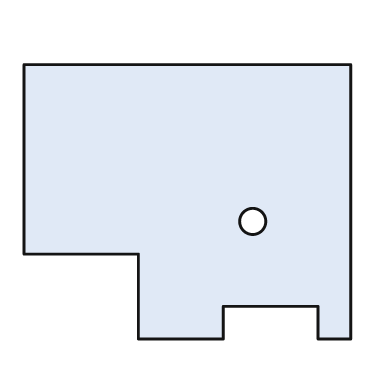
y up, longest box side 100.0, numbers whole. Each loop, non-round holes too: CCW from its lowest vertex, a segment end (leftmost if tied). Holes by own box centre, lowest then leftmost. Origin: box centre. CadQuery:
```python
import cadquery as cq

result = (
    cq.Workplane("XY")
    .moveTo(-15.0, -42.0)
    .lineTo(11.0, -42.0)
    .lineTo(11.0, -32.0)
    .lineTo(40.0, -32.0)
    .lineTo(40.0, -42.0)
    .lineTo(50.0, -42.0)
    .lineTo(50.0, 42.0)
    .lineTo(-50.0, 42.0)
    .lineTo(-50.0, -16.0)
    .lineTo(-15.0, -16.0)
    .close()
    .moveTo(20.0, -6.0)
    .circle(4.0)
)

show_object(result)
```